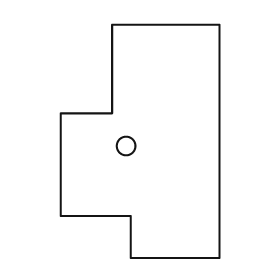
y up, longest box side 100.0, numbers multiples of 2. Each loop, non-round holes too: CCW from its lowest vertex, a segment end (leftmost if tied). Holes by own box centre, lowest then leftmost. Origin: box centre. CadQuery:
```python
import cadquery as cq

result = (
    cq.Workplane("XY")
    .moveTo(-4.0, -50.0)
    .lineTo(34.0, -50.0)
    .lineTo(34.0, 50.0)
    .lineTo(-12.0, 50.0)
    .lineTo(-12.0, 12.0)
    .lineTo(-34.0, 12.0)
    .lineTo(-34.0, -32.0)
    .lineTo(-4.0, -32.0)
    .close()
    .moveTo(-6.0, -2.0)
    .circle(4.0)
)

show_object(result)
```